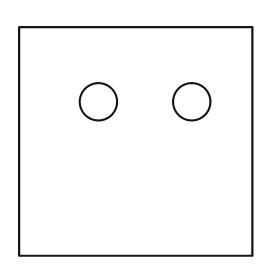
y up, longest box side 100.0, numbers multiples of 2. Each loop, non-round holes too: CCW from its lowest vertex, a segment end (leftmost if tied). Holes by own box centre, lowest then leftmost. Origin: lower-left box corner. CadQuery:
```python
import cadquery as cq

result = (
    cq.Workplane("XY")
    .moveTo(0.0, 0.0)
    .lineTo(100.0, 0.0)
    .lineTo(100.0, 98.0)
    .lineTo(0.0, 98.0)
    .close()
    .moveTo(34.0, 66.0)
    .circle(8.0)
    .moveTo(74.0, 66.0)
    .circle(8.0)
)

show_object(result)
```